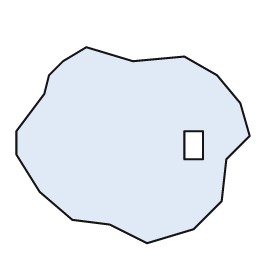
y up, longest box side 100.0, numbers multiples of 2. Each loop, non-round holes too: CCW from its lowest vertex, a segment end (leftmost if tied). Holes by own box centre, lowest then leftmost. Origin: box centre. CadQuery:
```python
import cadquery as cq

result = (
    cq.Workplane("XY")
    .moveTo(6.0, -42.0)
    .lineTo(26.0, -36.0)
    .lineTo(38.0, -24.0)
    .lineTo(40.0, -6.0)
    .lineTo(50.0, 4.0)
    .lineTo(46.0, 18.0)
    .lineTo(36.0, 30.0)
    .lineTo(22.0, 38.0)
    .lineTo(0.0, 36.0)
    .lineTo(-20.0, 42.0)
    .lineTo(-30.0, 36.0)
    .lineTo(-36.0, 30.0)
    .lineTo(-38.0, 22.0)
    .lineTo(-50.0, 6.0)
    .lineTo(-50.0, -4.0)
    .lineTo(-40.0, -20.0)
    .lineTo(-26.0, -32.0)
    .lineTo(-10.0, -34.0)
    .close()
    .moveTo(22.0, -6.0)
    .lineTo(30.0, -6.0)
    .lineTo(30.0, 6.0)
    .lineTo(22.0, 6.0)
    .close()
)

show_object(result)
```